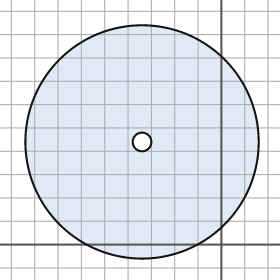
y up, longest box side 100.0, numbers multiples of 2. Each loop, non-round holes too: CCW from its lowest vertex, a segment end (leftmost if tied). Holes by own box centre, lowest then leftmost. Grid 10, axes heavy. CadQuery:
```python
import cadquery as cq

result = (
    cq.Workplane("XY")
    .moveTo(-34.0, 44.0)
    .circle(50.0)
    .moveTo(-34.0, 44.0)
    .circle(4.0)
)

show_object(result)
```